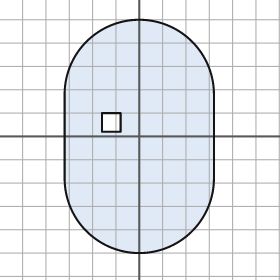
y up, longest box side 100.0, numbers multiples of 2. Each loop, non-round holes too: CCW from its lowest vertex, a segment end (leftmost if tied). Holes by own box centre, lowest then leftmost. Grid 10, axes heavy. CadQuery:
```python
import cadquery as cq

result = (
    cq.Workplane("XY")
    .moveTo(-32.0, -18.0)
    .threePointArc((0.0, -50.0), (32.0, -18.0))
    .lineTo(32.0, 18.0)
    .threePointArc((0.0, 50.0), (-32.0, 18.0))
    .close()
    .moveTo(-16.0, 2.0)
    .lineTo(-8.0, 2.0)
    .lineTo(-8.0, 10.0)
    .lineTo(-16.0, 10.0)
    .close()
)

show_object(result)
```